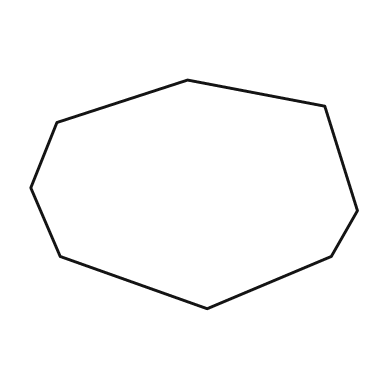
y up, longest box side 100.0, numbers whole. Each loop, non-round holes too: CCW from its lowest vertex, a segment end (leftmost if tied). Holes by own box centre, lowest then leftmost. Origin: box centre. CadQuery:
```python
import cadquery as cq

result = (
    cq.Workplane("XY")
    .moveTo(4.0, -35.0)
    .lineTo(42.0, -19.0)
    .lineTo(50.0, -5.0)
    .lineTo(40.0, 27.0)
    .lineTo(-2.0, 35.0)
    .lineTo(-42.0, 22.0)
    .lineTo(-50.0, 2.0)
    .lineTo(-41.0, -19.0)
    .close()
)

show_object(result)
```